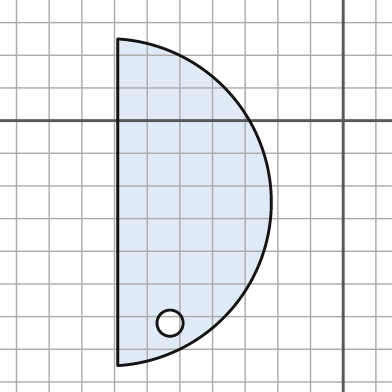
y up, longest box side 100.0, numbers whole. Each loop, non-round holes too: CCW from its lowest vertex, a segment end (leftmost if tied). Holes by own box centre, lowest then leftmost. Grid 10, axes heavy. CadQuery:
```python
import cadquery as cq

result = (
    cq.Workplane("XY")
    .moveTo(-69.0, -75.0)
    .threePointArc((-22.0, -25.0), (-69.0, 25.0))
    .close()
    .moveTo(-53.0, -62.0)
    .circle(4.0)
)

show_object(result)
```